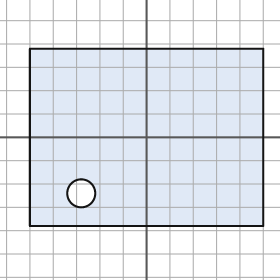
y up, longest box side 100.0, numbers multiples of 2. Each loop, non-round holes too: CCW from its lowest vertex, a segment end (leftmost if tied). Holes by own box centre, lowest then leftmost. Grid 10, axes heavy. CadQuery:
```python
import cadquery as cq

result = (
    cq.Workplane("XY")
    .moveTo(-50.0, -38.0)
    .lineTo(50.0, -38.0)
    .lineTo(50.0, 38.0)
    .lineTo(-50.0, 38.0)
    .close()
    .moveTo(-28.0, -24.0)
    .circle(6.0)
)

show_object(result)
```